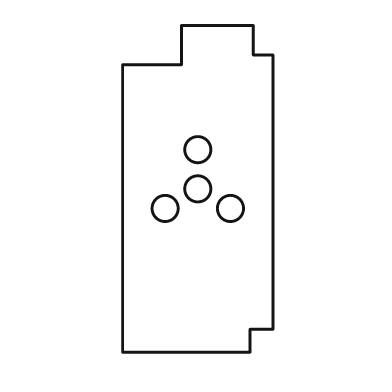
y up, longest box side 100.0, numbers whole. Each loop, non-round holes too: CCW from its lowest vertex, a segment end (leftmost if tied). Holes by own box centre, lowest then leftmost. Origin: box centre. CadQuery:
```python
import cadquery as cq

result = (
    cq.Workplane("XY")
    .moveTo(-23.0, -50.0)
    .lineTo(16.0, -50.0)
    .lineTo(16.0, -43.0)
    .lineTo(23.0, -43.0)
    .lineTo(23.0, 41.0)
    .lineTo(17.0, 41.0)
    .lineTo(17.0, 50.0)
    .lineTo(-5.0, 50.0)
    .lineTo(-5.0, 38.0)
    .lineTo(-23.0, 38.0)
    .close()
    .moveTo(-10.0, -6.0)
    .circle(4.0)
    .moveTo(10.0, -6.0)
    .circle(4.0)
    .moveTo(0.0, 0.0)
    .circle(4.0)
    .moveTo(0.0, 12.0)
    .circle(4.0)
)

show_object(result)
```